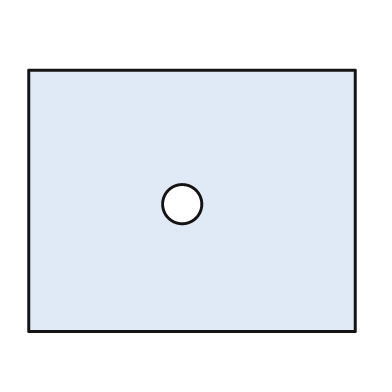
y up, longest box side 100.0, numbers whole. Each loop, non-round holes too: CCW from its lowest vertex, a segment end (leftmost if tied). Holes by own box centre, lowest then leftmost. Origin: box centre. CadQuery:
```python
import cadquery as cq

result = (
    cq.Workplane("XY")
    .moveTo(-50.0, -40.0)
    .lineTo(50.0, -40.0)
    .lineTo(50.0, 40.0)
    .lineTo(-50.0, 40.0)
    .close()
    .moveTo(-3.0, -1.0)
    .circle(6.0)
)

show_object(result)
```